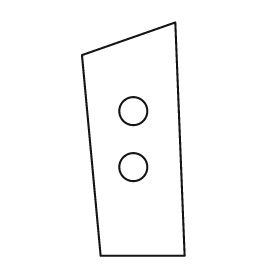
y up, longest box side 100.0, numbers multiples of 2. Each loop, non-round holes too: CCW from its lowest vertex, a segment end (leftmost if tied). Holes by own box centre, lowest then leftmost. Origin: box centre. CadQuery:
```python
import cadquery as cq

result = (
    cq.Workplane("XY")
    .moveTo(-14.0, -50.0)
    .lineTo(22.0, -50.0)
    .lineTo(18.0, 50.0)
    .lineTo(-22.0, 36.0)
    .close()
    .moveTo(0.0, -12.0)
    .circle(6.0)
    .moveTo(0.0, 12.0)
    .circle(6.0)
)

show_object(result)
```